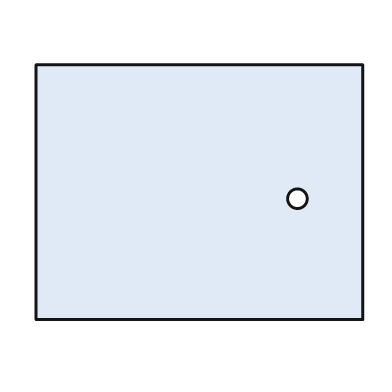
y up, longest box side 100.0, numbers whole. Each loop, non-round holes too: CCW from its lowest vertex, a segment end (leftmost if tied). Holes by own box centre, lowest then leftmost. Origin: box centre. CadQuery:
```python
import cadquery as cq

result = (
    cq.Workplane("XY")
    .moveTo(-50.0, -39.0)
    .lineTo(50.0, -39.0)
    .lineTo(50.0, 39.0)
    .lineTo(-50.0, 39.0)
    .close()
    .moveTo(30.0, -2.0)
    .circle(3.0)
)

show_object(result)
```